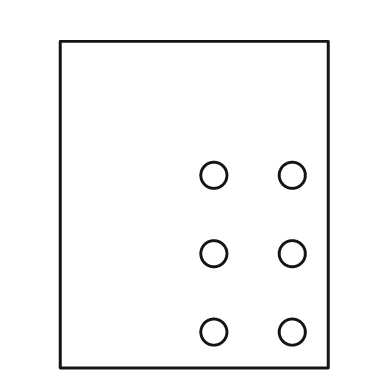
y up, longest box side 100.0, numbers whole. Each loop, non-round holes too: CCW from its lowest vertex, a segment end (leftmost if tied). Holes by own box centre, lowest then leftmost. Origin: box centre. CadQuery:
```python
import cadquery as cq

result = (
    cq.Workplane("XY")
    .moveTo(-41.0, -50.0)
    .lineTo(41.0, -50.0)
    .lineTo(41.0, 50.0)
    .lineTo(-41.0, 50.0)
    .close()
    .moveTo(6.0, -39.0)
    .circle(4.0)
    .moveTo(30.0, -39.0)
    .circle(4.0)
    .moveTo(6.0, -15.0)
    .circle(4.0)
    .moveTo(30.0, -15.0)
    .circle(4.0)
    .moveTo(6.0, 9.0)
    .circle(4.0)
    .moveTo(30.0, 9.0)
    .circle(4.0)
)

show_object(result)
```